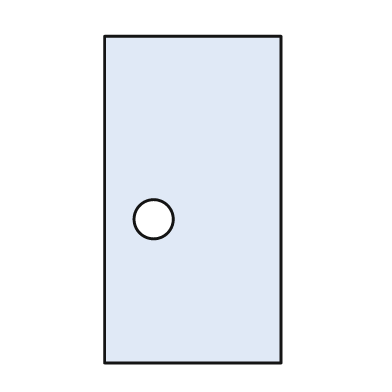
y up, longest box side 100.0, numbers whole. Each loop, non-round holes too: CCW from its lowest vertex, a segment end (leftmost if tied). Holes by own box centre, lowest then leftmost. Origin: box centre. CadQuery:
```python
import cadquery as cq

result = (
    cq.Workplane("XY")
    .moveTo(-27.0, -50.0)
    .lineTo(27.0, -50.0)
    .lineTo(27.0, 50.0)
    .lineTo(-27.0, 50.0)
    .close()
    .moveTo(-12.0, -6.0)
    .circle(6.0)
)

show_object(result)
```